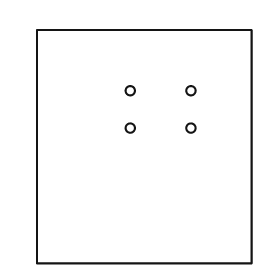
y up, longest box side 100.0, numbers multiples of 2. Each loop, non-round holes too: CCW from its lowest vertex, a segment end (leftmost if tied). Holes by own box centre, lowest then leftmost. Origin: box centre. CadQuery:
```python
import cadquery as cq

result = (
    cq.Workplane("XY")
    .moveTo(-46.0, -50.0)
    .lineTo(46.0, -50.0)
    .lineTo(46.0, 50.0)
    .lineTo(-46.0, 50.0)
    .close()
    .moveTo(-6.0, 8.0)
    .circle(2.0)
    .moveTo(20.0, 8.0)
    .circle(2.0)
    .moveTo(-6.0, 24.0)
    .circle(2.0)
    .moveTo(20.0, 24.0)
    .circle(2.0)
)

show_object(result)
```